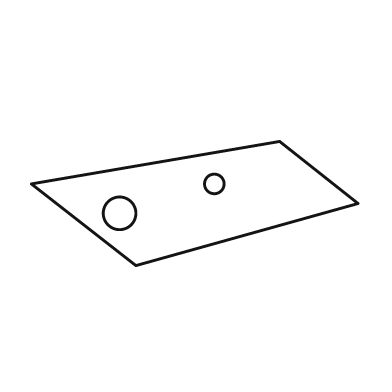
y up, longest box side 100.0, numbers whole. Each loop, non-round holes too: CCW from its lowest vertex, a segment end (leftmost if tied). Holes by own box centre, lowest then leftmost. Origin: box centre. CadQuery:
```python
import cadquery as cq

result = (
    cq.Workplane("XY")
    .moveTo(-18.0, -19.0)
    .lineTo(50.0, 0.0)
    .lineTo(26.0, 19.0)
    .lineTo(-50.0, 6.0)
    .close()
    .moveTo(-23.0, -3.0)
    .circle(5.0)
    .moveTo(6.0, 6.0)
    .circle(3.0)
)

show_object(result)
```